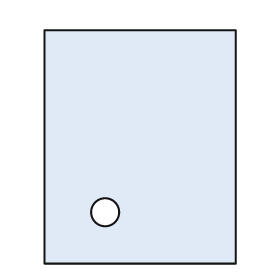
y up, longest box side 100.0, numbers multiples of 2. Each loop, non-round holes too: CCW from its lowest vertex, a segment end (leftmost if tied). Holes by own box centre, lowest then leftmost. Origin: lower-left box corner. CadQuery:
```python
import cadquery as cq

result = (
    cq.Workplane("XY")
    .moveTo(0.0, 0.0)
    .lineTo(82.0, 0.0)
    .lineTo(82.0, 100.0)
    .lineTo(0.0, 100.0)
    .close()
    .moveTo(26.0, 22.0)
    .circle(6.0)
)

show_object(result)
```